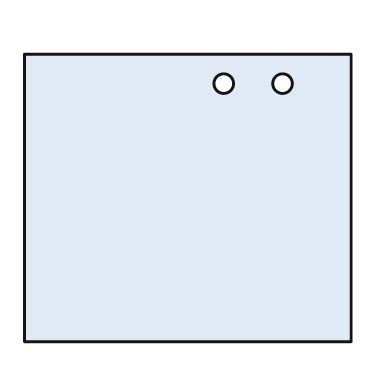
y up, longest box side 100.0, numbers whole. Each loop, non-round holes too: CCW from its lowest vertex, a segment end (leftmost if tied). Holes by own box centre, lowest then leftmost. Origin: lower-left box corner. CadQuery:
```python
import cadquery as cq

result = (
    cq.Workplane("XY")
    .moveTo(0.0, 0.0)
    .lineTo(100.0, 0.0)
    .lineTo(100.0, 88.0)
    .lineTo(0.0, 88.0)
    .close()
    .moveTo(61.0, 79.0)
    .circle(3.0)
    .moveTo(79.0, 79.0)
    .circle(3.0)
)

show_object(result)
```